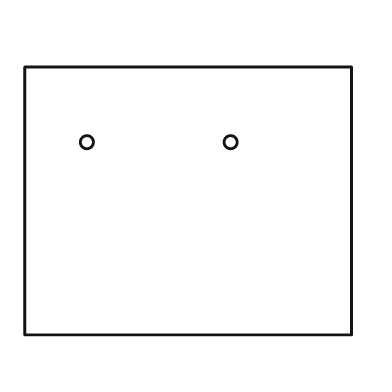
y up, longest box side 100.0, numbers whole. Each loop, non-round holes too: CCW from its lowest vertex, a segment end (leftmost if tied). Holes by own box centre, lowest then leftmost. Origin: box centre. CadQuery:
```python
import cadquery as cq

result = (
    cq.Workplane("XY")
    .moveTo(-50.0, -41.0)
    .lineTo(50.0, -41.0)
    .lineTo(50.0, 41.0)
    .lineTo(-50.0, 41.0)
    .close()
    .moveTo(-31.0, 18.0)
    .circle(2.0)
    .moveTo(13.0, 18.0)
    .circle(2.0)
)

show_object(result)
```